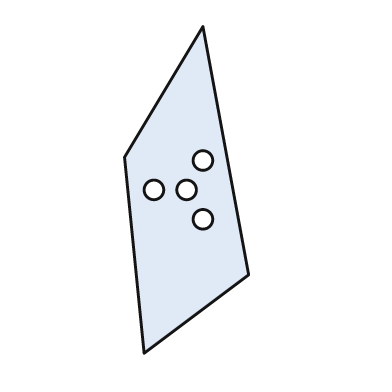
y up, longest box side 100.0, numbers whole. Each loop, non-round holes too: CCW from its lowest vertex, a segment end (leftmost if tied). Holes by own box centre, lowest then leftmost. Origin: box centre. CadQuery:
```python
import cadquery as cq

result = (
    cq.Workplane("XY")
    .moveTo(-13.0, -50.0)
    .lineTo(19.0, -26.0)
    .lineTo(5.0, 50.0)
    .lineTo(-19.0, 10.0)
    .close()
    .moveTo(5.0, -9.0)
    .circle(3.0)
    .moveTo(-10.0, 0.0)
    .circle(3.0)
    .moveTo(0.0, 0.0)
    .circle(3.0)
    .moveTo(5.0, 9.0)
    .circle(3.0)
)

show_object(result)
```